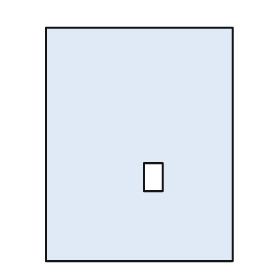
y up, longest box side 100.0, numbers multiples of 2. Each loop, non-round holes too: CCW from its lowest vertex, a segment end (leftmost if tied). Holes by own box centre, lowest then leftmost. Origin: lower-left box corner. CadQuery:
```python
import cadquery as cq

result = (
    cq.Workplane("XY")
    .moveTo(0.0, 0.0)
    .lineTo(80.0, 0.0)
    .lineTo(80.0, 100.0)
    .lineTo(0.0, 100.0)
    .close()
    .moveTo(42.0, 30.0)
    .lineTo(50.0, 30.0)
    .lineTo(50.0, 42.0)
    .lineTo(42.0, 42.0)
    .close()
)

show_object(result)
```